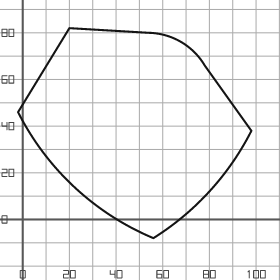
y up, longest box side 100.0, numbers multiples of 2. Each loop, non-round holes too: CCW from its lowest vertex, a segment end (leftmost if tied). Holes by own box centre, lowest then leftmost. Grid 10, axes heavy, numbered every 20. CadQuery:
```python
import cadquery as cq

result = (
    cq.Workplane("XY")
    .moveTo(56.0, -8.0)
    .threePointArc((80.0, 12.0), (98.0, 38.0))
    .lineTo(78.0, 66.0)
    .threePointArc((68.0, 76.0), (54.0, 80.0))
    .lineTo(20.0, 82.0)
    .lineTo(-2.0, 46.0)
    .threePointArc((22.0, 14.0), (56.0, -8.0))
    .close()
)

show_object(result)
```